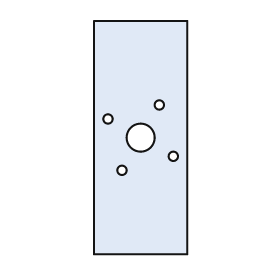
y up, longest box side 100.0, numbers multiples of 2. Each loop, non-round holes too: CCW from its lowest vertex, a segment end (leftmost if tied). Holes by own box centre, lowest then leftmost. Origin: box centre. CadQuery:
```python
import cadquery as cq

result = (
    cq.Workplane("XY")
    .moveTo(-20.0, -50.0)
    .lineTo(20.0, -50.0)
    .lineTo(20.0, 50.0)
    .lineTo(-20.0, 50.0)
    .close()
    .moveTo(-8.0, -14.0)
    .circle(2.0)
    .moveTo(14.0, -8.0)
    .circle(2.0)
    .moveTo(0.0, 0.0)
    .circle(6.0)
    .moveTo(-14.0, 8.0)
    .circle(2.0)
    .moveTo(8.0, 14.0)
    .circle(2.0)
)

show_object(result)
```